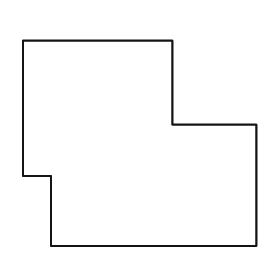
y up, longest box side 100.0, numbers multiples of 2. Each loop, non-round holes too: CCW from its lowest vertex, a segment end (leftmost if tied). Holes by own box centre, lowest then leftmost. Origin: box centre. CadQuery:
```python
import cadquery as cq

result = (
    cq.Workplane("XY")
    .moveTo(-38.0, -44.0)
    .lineTo(50.0, -44.0)
    .lineTo(50.0, 8.0)
    .lineTo(14.0, 8.0)
    .lineTo(14.0, 44.0)
    .lineTo(-50.0, 44.0)
    .lineTo(-50.0, -14.0)
    .lineTo(-38.0, -14.0)
    .close()
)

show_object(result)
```